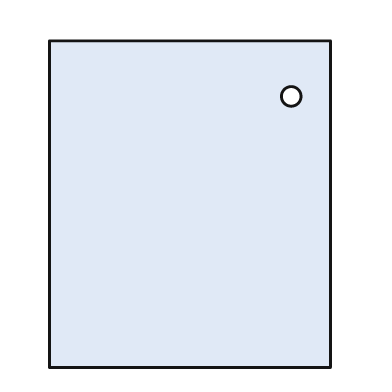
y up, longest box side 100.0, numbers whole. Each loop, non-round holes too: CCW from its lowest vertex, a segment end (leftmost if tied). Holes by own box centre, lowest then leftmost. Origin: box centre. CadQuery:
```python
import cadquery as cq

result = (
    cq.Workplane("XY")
    .moveTo(-43.0, -50.0)
    .lineTo(43.0, -50.0)
    .lineTo(43.0, 50.0)
    .lineTo(-43.0, 50.0)
    .close()
    .moveTo(31.0, 33.0)
    .circle(3.0)
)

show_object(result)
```